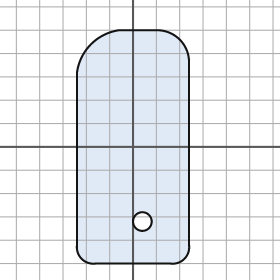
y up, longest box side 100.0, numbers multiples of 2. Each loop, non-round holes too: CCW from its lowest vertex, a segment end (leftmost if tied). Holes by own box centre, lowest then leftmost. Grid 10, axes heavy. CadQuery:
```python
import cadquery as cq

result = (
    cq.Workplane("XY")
    .moveTo(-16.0, -50.0)
    .lineTo(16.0, -50.0)
    .threePointArc((22.0, -48.0), (24.0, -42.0))
    .lineTo(24.0, 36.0)
    .threePointArc((20.0, 46.0), (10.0, 50.0))
    .lineTo(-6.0, 50.0)
    .threePointArc((-18.0, 44.0), (-24.0, 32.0))
    .lineTo(-24.0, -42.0)
    .threePointArc((-22.0, -48.0), (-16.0, -50.0))
    .close()
    .moveTo(4.0, -32.0)
    .circle(4.0)
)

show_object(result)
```